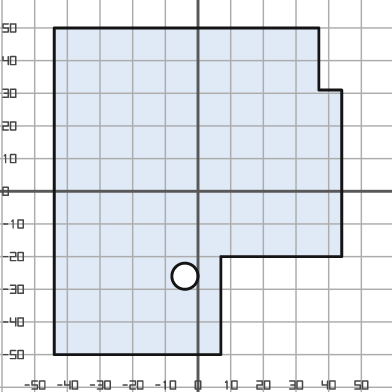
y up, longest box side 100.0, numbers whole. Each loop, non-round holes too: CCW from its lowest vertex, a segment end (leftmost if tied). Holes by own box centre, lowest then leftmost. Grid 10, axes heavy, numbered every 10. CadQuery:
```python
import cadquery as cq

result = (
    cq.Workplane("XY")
    .moveTo(-44.0, -50.0)
    .lineTo(7.0, -50.0)
    .lineTo(7.0, -20.0)
    .lineTo(44.0, -20.0)
    .lineTo(44.0, 31.0)
    .lineTo(37.0, 31.0)
    .lineTo(37.0, 50.0)
    .lineTo(-44.0, 50.0)
    .close()
    .moveTo(-4.0, -26.0)
    .circle(4.0)
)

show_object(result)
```